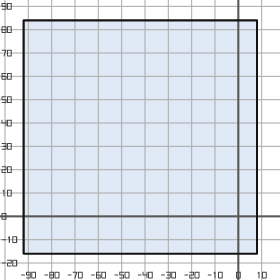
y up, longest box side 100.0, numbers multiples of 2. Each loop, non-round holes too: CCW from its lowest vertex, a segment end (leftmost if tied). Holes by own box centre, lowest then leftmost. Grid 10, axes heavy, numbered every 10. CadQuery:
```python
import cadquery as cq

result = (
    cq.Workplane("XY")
    .moveTo(-92.0, -16.0)
    .lineTo(8.0, -16.0)
    .lineTo(8.0, 84.0)
    .lineTo(-92.0, 84.0)
    .close()
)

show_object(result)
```